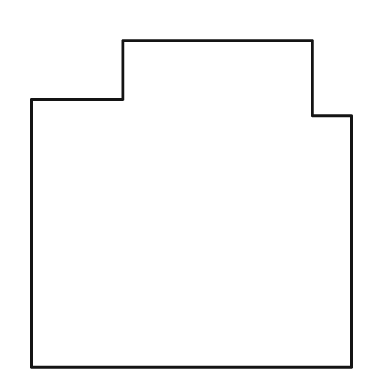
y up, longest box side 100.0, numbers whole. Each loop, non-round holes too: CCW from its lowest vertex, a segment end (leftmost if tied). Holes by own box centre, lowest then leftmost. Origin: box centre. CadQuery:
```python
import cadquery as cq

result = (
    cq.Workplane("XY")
    .moveTo(-49.0, -50.0)
    .lineTo(49.0, -50.0)
    .lineTo(49.0, 27.0)
    .lineTo(37.0, 27.0)
    .lineTo(37.0, 50.0)
    .lineTo(-21.0, 50.0)
    .lineTo(-21.0, 32.0)
    .lineTo(-49.0, 32.0)
    .close()
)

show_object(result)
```